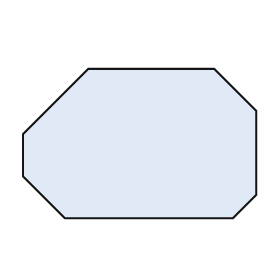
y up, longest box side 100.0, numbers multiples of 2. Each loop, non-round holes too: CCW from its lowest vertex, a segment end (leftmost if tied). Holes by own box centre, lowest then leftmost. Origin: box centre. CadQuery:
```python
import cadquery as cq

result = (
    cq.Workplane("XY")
    .moveTo(-32.0, -32.0)
    .lineTo(40.0, -32.0)
    .lineTo(50.0, -22.0)
    .lineTo(50.0, 14.0)
    .lineTo(32.0, 32.0)
    .lineTo(-22.0, 32.0)
    .lineTo(-50.0, 4.0)
    .lineTo(-50.0, -14.0)
    .close()
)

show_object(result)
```